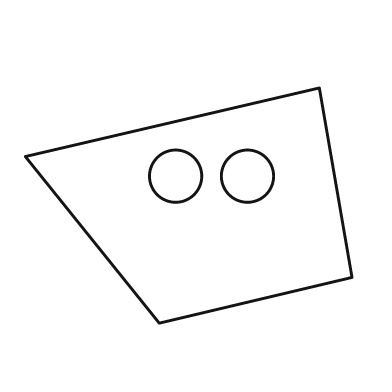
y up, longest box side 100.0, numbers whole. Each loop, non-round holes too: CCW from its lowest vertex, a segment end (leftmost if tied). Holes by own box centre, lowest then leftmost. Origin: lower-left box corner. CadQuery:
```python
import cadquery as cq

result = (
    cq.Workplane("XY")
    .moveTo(41.0, 0.0)
    .lineTo(100.0, 14.0)
    .lineTo(90.0, 72.0)
    .lineTo(0.0, 51.0)
    .close()
    .moveTo(46.0, 45.0)
    .circle(8.0)
    .moveTo(68.0, 45.0)
    .circle(8.0)
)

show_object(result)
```